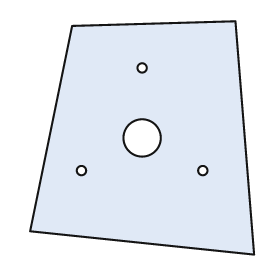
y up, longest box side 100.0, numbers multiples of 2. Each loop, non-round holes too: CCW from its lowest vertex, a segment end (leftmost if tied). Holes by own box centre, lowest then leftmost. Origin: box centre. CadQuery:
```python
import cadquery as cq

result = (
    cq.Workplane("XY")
    .moveTo(48.0, -50.0)
    .lineTo(40.0, 50.0)
    .lineTo(-30.0, 48.0)
    .lineTo(-48.0, -40.0)
    .close()
    .moveTo(-26.0, -14.0)
    .circle(2.0)
    .moveTo(26.0, -14.0)
    .circle(2.0)
    .moveTo(0.0, 0.0)
    .circle(8.0)
    .moveTo(0.0, 30.0)
    .circle(2.0)
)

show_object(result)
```